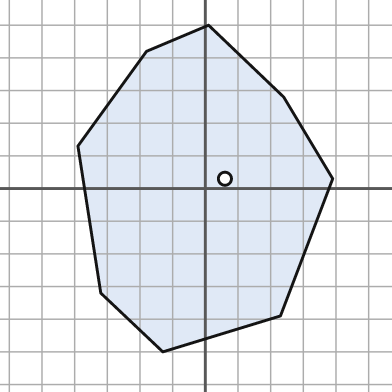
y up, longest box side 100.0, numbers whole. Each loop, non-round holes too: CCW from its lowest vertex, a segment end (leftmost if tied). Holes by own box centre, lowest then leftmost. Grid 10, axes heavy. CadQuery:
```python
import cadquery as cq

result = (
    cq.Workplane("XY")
    .moveTo(-13.0, -50.0)
    .lineTo(23.0, -39.0)
    .lineTo(39.0, 3.0)
    .lineTo(24.0, 28.0)
    .lineTo(1.0, 50.0)
    .lineTo(-18.0, 42.0)
    .lineTo(-39.0, 13.0)
    .lineTo(-32.0, -32.0)
    .close()
    .moveTo(6.0, 3.0)
    .circle(2.0)
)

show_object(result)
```